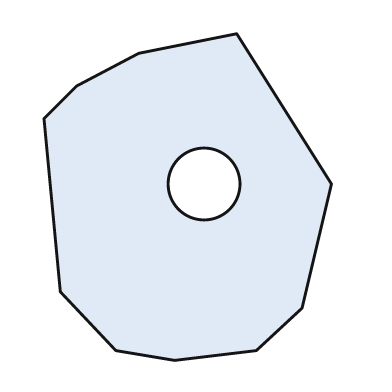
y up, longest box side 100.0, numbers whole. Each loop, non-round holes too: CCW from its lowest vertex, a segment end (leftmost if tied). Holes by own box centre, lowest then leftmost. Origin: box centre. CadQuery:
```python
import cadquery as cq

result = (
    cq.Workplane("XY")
    .moveTo(-4.0, -50.0)
    .lineTo(21.0, -47.0)
    .lineTo(35.0, -34.0)
    .lineTo(44.0, 4.0)
    .lineTo(15.0, 50.0)
    .lineTo(-15.0, 44.0)
    .lineTo(-34.0, 34.0)
    .lineTo(-44.0, 24.0)
    .lineTo(-39.0, -29.0)
    .lineTo(-22.0, -47.0)
    .close()
    .moveTo(5.0, 4.0)
    .circle(11.0)
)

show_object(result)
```